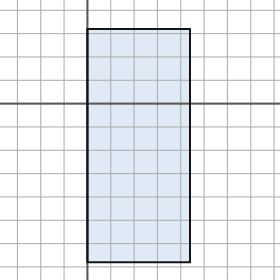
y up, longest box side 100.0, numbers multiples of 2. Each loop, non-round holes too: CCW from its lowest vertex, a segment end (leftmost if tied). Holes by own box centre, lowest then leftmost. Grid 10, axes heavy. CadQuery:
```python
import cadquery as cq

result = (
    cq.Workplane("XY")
    .moveTo(0.0, -68.0)
    .lineTo(44.0, -68.0)
    .lineTo(44.0, 32.0)
    .lineTo(0.0, 32.0)
    .close()
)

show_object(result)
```